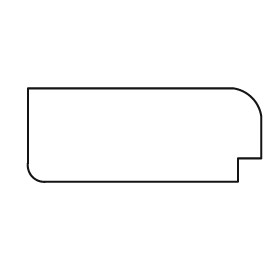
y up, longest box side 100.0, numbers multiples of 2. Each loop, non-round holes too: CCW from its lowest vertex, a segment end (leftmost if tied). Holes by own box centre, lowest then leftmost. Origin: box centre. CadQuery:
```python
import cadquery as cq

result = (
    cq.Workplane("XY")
    .moveTo(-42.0, -20.0)
    .lineTo(40.0, -20.0)
    .lineTo(40.0, -10.0)
    .lineTo(50.0, -10.0)
    .lineTo(50.0, 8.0)
    .threePointArc((46.0, 16.0), (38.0, 20.0))
    .lineTo(-50.0, 20.0)
    .lineTo(-50.0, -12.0)
    .threePointArc((-48.0, -18.0), (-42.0, -20.0))
    .close()
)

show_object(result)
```